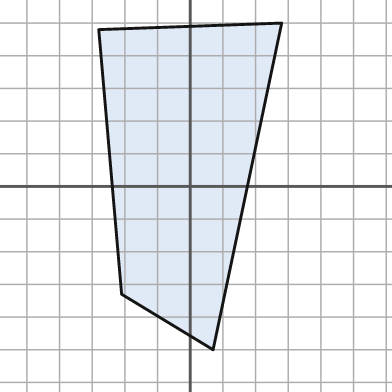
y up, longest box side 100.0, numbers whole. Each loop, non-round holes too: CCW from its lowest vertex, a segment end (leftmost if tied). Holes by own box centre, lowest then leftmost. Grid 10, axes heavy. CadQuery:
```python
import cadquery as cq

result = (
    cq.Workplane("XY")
    .moveTo(7.0, -50.0)
    .lineTo(28.0, 50.0)
    .lineTo(-28.0, 48.0)
    .lineTo(-21.0, -33.0)
    .close()
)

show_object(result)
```